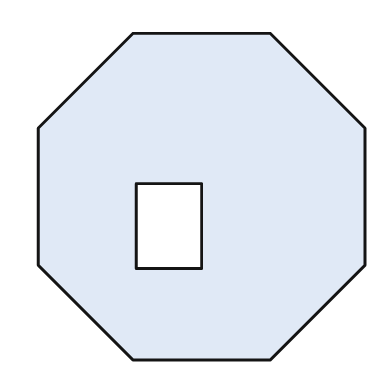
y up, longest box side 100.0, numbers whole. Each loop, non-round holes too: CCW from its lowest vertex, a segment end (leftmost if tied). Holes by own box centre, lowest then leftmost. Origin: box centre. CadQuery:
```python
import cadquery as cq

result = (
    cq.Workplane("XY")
    .moveTo(-21.0, -50.0)
    .lineTo(21.0, -50.0)
    .lineTo(50.0, -21.0)
    .lineTo(50.0, 21.0)
    .lineTo(21.0, 50.0)
    .lineTo(-21.0, 50.0)
    .lineTo(-50.0, 21.0)
    .lineTo(-50.0, -21.0)
    .close()
    .moveTo(-20.0, -22.0)
    .lineTo(0.0, -22.0)
    .lineTo(0.0, 4.0)
    .lineTo(-20.0, 4.0)
    .close()
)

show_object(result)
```